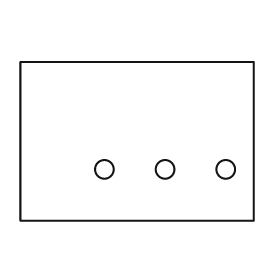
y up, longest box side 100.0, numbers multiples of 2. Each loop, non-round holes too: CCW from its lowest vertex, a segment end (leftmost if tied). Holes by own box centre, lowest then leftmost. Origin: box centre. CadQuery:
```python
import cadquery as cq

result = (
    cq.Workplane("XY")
    .moveTo(-50.0, -34.0)
    .lineTo(50.0, -34.0)
    .lineTo(50.0, 34.0)
    .lineTo(-50.0, 34.0)
    .close()
    .moveTo(-14.0, -12.0)
    .circle(4.0)
    .moveTo(12.0, -12.0)
    .circle(4.0)
    .moveTo(38.0, -12.0)
    .circle(4.0)
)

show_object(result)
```